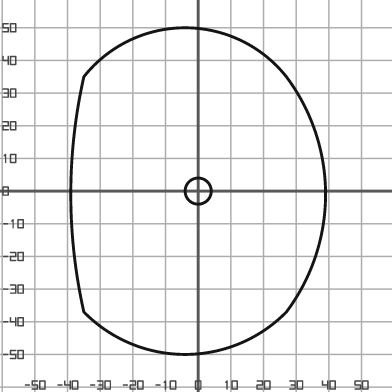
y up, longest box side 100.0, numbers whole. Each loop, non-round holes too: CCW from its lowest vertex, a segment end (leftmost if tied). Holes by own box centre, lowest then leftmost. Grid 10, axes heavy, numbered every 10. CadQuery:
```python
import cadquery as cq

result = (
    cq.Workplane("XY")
    .moveTo(-35.0, -37.0)
    .threePointArc((-4.0, -50.0), (27.0, -37.0))
    .threePointArc((39.0, -1.0), (27.0, 35.0))
    .threePointArc((-4.0, 50.0), (-35.0, 35.0))
    .threePointArc((-39.0, -1.0), (-35.0, -37.0))
    .close()
    .moveTo(0.0, 0.0)
    .circle(4.0)
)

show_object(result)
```